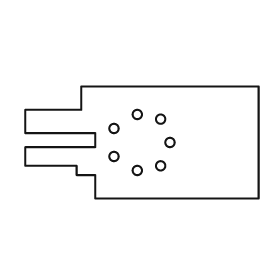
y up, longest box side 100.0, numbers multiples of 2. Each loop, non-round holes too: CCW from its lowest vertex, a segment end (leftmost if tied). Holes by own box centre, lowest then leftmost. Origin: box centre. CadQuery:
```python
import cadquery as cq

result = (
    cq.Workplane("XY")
    .moveTo(-20.0, -24.0)
    .lineTo(50.0, -24.0)
    .lineTo(50.0, 24.0)
    .lineTo(-26.0, 24.0)
    .lineTo(-26.0, 14.0)
    .lineTo(-50.0, 14.0)
    .lineTo(-50.0, 4.0)
    .lineTo(-20.0, 4.0)
    .lineTo(-20.0, -2.0)
    .lineTo(-50.0, -2.0)
    .lineTo(-50.0, -10.0)
    .lineTo(-28.0, -10.0)
    .lineTo(-28.0, -14.0)
    .lineTo(-20.0, -14.0)
    .close()
    .moveTo(-2.0, -12.0)
    .circle(2.0)
    .moveTo(8.0, -10.0)
    .circle(2.0)
    .moveTo(-12.0, -6.0)
    .circle(2.0)
    .moveTo(12.0, 0.0)
    .circle(2.0)
    .moveTo(-12.0, 6.0)
    .circle(2.0)
    .moveTo(8.0, 10.0)
    .circle(2.0)
    .moveTo(-2.0, 12.0)
    .circle(2.0)
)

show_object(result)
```